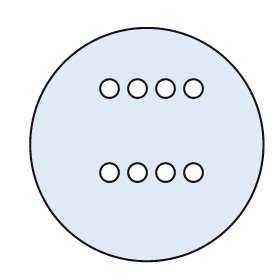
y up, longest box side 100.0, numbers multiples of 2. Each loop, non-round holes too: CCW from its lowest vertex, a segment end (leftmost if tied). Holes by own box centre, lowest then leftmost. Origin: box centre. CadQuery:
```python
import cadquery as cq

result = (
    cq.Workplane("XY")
    .moveTo(0.0, 0.0)
    .circle(50.0)
    .moveTo(-16.0, -12.0)
    .circle(4.0)
    .moveTo(-4.0, -12.0)
    .circle(4.0)
    .moveTo(8.0, -12.0)
    .circle(4.0)
    .moveTo(20.0, -12.0)
    .circle(4.0)
    .moveTo(-16.0, 24.0)
    .circle(4.0)
    .moveTo(-4.0, 24.0)
    .circle(4.0)
    .moveTo(8.0, 24.0)
    .circle(4.0)
    .moveTo(20.0, 24.0)
    .circle(4.0)
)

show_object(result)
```